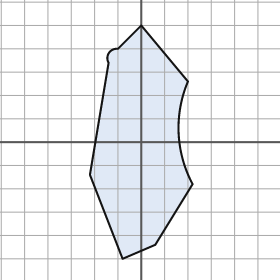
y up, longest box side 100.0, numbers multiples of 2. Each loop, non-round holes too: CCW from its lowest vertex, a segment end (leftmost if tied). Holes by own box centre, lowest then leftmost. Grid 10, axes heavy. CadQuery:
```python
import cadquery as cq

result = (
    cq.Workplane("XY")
    .moveTo(-8.0, -50.0)
    .lineTo(6.0, -44.0)
    .lineTo(22.0, -18.0)
    .threePointArc((16.0, 4.0), (20.0, 26.0))
    .lineTo(0.0, 50.0)
    .lineTo(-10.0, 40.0)
    .threePointArc((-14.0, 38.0), (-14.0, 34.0))
    .lineTo(-22.0, -14.0)
    .close()
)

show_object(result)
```